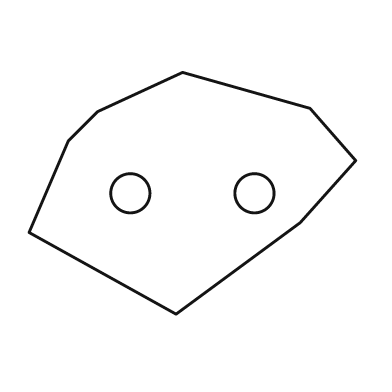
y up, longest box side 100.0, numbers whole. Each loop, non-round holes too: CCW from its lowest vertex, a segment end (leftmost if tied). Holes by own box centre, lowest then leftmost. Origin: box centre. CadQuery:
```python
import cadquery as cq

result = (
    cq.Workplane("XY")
    .moveTo(-5.0, -37.0)
    .lineTo(33.0, -9.0)
    .lineTo(50.0, 10.0)
    .lineTo(36.0, 26.0)
    .lineTo(-3.0, 37.0)
    .lineTo(-29.0, 25.0)
    .lineTo(-38.0, 16.0)
    .lineTo(-50.0, -12.0)
    .close()
    .moveTo(-19.0, 0.0)
    .circle(6.0)
    .moveTo(19.0, 0.0)
    .circle(6.0)
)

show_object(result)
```